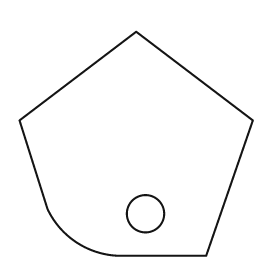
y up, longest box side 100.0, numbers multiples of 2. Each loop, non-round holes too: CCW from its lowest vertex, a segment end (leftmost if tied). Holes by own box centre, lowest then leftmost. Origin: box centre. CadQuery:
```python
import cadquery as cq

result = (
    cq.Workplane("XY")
    .moveTo(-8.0, -48.0)
    .lineTo(30.0, -48.0)
    .lineTo(50.0, 10.0)
    .lineTo(0.0, 48.0)
    .lineTo(-50.0, 10.0)
    .lineTo(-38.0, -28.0)
    .threePointArc((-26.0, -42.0), (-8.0, -48.0))
    .close()
    .moveTo(4.0, -30.0)
    .circle(8.0)
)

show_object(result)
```